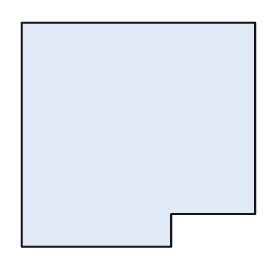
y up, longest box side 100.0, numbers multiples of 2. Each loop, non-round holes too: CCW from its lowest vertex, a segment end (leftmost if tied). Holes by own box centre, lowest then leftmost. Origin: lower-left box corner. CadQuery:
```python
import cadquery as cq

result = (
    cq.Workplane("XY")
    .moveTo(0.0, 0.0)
    .lineTo(64.0, 0.0)
    .lineTo(64.0, 14.0)
    .lineTo(100.0, 14.0)
    .lineTo(100.0, 96.0)
    .lineTo(0.0, 96.0)
    .close()
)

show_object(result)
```